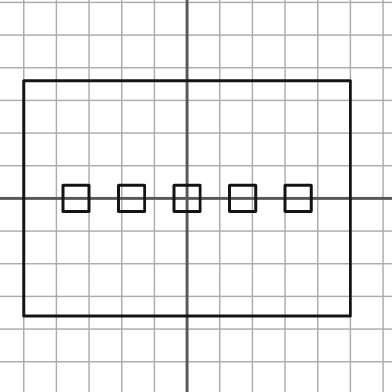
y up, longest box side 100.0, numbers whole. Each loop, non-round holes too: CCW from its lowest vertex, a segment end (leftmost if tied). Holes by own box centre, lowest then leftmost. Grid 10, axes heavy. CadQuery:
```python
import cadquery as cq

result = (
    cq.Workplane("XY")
    .moveTo(-50.0, -36.0)
    .lineTo(50.0, -36.0)
    .lineTo(50.0, 36.0)
    .lineTo(-50.0, 36.0)
    .close()
    .moveTo(-38.0, -4.0)
    .lineTo(-30.0, -4.0)
    .lineTo(-30.0, 4.0)
    .lineTo(-38.0, 4.0)
    .close()
    .moveTo(-21.0, -4.0)
    .lineTo(-13.0, -4.0)
    .lineTo(-13.0, 4.0)
    .lineTo(-21.0, 4.0)
    .close()
    .moveTo(-4.0, -4.0)
    .lineTo(4.0, -4.0)
    .lineTo(4.0, 4.0)
    .lineTo(-4.0, 4.0)
    .close()
    .moveTo(13.0, -4.0)
    .lineTo(21.0, -4.0)
    .lineTo(21.0, 4.0)
    .lineTo(13.0, 4.0)
    .close()
    .moveTo(30.0, -4.0)
    .lineTo(38.0, -4.0)
    .lineTo(38.0, 4.0)
    .lineTo(30.0, 4.0)
    .close()
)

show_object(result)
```